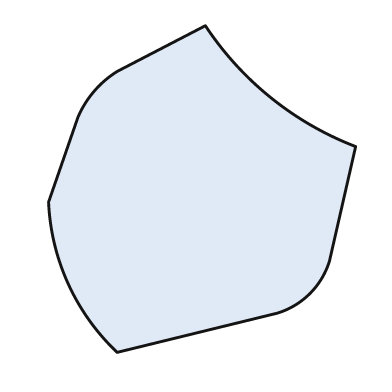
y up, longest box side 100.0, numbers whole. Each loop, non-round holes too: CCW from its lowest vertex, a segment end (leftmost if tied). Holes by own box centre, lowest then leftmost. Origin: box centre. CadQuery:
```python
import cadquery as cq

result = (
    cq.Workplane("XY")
    .moveTo(-26.0, -50.0)
    .lineTo(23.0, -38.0)
    .threePointArc((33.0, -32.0), (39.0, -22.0))
    .lineTo(47.0, 13.0)
    .threePointArc((21.0, 28.0), (1.0, 50.0))
    .lineTo(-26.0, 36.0)
    .threePointArc((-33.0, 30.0), (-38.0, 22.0))
    .lineTo(-47.0, -4.0)
    .threePointArc((-41.0, -29.0), (-26.0, -50.0))
    .close()
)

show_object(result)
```